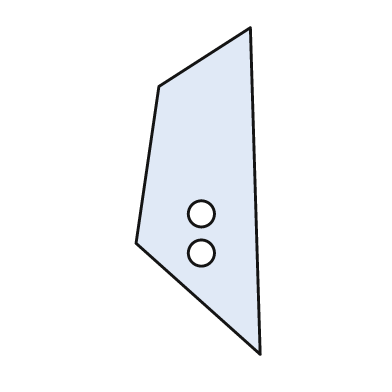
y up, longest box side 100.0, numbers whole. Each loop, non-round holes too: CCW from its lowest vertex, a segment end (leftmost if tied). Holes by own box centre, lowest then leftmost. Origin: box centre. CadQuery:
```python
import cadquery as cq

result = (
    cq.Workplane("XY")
    .moveTo(19.0, -50.0)
    .lineTo(16.0, 50.0)
    .lineTo(-12.0, 32.0)
    .lineTo(-19.0, -16.0)
    .close()
    .moveTo(1.0, -19.0)
    .circle(4.0)
    .moveTo(1.0, -7.0)
    .circle(4.0)
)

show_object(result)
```